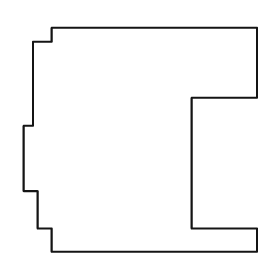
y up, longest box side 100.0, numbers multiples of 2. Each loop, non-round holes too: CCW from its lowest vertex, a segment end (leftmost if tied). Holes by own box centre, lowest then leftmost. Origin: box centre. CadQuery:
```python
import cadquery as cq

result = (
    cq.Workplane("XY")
    .moveTo(-38.0, -48.0)
    .lineTo(50.0, -48.0)
    .lineTo(50.0, -38.0)
    .lineTo(22.0, -38.0)
    .lineTo(22.0, 18.0)
    .lineTo(50.0, 18.0)
    .lineTo(50.0, 48.0)
    .lineTo(-38.0, 48.0)
    .lineTo(-38.0, 42.0)
    .lineTo(-46.0, 42.0)
    .lineTo(-46.0, 6.0)
    .lineTo(-50.0, 6.0)
    .lineTo(-50.0, -22.0)
    .lineTo(-44.0, -22.0)
    .lineTo(-44.0, -38.0)
    .lineTo(-38.0, -38.0)
    .close()
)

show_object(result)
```